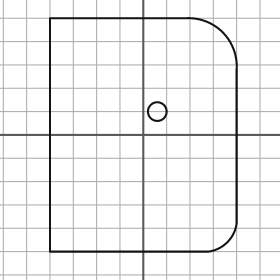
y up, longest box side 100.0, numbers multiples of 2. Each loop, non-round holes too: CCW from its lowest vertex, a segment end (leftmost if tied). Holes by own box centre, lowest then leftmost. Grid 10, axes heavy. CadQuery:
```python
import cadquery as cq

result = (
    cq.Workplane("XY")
    .moveTo(-40.0, -50.0)
    .lineTo(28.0, -50.0)
    .threePointArc((36.0, -46.0), (40.0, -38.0))
    .lineTo(40.0, 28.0)
    .threePointArc((34.0, 44.0), (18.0, 50.0))
    .lineTo(-40.0, 50.0)
    .close()
    .moveTo(6.0, 10.0)
    .circle(4.0)
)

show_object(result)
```